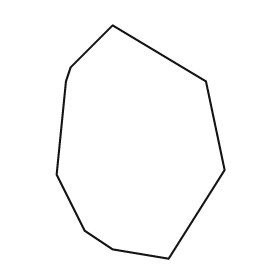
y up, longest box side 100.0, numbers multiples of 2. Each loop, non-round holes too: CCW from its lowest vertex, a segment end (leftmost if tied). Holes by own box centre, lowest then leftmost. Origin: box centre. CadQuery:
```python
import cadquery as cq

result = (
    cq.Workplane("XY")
    .moveTo(12.0, -50.0)
    .lineTo(36.0, -12.0)
    .lineTo(28.0, 26.0)
    .lineTo(-12.0, 50.0)
    .lineTo(-30.0, 32.0)
    .lineTo(-32.0, 26.0)
    .lineTo(-36.0, -14.0)
    .lineTo(-24.0, -38.0)
    .lineTo(-12.0, -46.0)
    .close()
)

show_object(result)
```